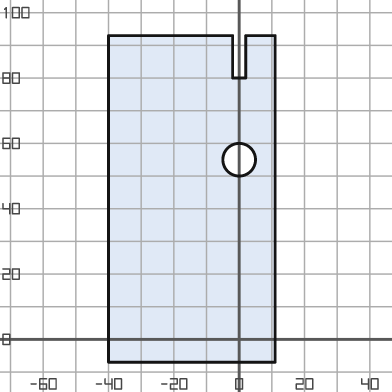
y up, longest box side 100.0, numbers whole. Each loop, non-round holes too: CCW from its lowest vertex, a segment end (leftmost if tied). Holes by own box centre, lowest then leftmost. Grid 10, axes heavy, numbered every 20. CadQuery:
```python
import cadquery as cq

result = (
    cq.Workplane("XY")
    .moveTo(-40.0, -7.0)
    .lineTo(11.0, -7.0)
    .lineTo(11.0, 93.0)
    .lineTo(2.0, 93.0)
    .lineTo(2.0, 80.0)
    .lineTo(-2.0, 80.0)
    .lineTo(-2.0, 93.0)
    .lineTo(-40.0, 93.0)
    .close()
    .moveTo(0.0, 55.0)
    .circle(5.0)
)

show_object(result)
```